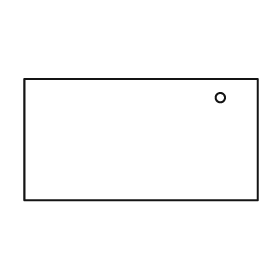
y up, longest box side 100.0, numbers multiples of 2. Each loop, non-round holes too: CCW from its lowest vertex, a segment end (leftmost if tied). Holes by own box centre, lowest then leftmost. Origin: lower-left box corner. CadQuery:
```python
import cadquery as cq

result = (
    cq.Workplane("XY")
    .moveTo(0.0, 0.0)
    .lineTo(100.0, 0.0)
    .lineTo(100.0, 52.0)
    .lineTo(0.0, 52.0)
    .close()
    .moveTo(84.0, 44.0)
    .circle(2.0)
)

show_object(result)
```